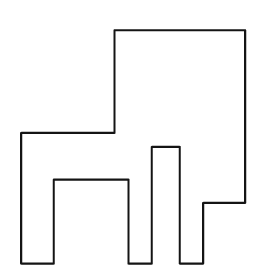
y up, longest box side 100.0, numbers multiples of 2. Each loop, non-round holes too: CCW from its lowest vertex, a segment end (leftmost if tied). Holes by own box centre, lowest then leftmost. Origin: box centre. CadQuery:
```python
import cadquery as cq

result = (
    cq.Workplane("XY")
    .moveTo(-48.0, -50.0)
    .lineTo(-34.0, -50.0)
    .lineTo(-34.0, -14.0)
    .lineTo(-2.0, -14.0)
    .lineTo(-2.0, -50.0)
    .lineTo(8.0, -50.0)
    .lineTo(8.0, 0.0)
    .lineTo(20.0, 0.0)
    .lineTo(20.0, -50.0)
    .lineTo(30.0, -50.0)
    .lineTo(30.0, -24.0)
    .lineTo(48.0, -24.0)
    .lineTo(48.0, 50.0)
    .lineTo(-8.0, 50.0)
    .lineTo(-8.0, 6.0)
    .lineTo(-48.0, 6.0)
    .close()
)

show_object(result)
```